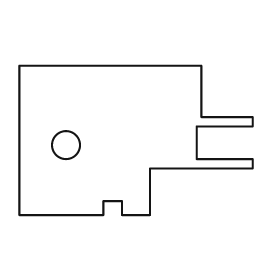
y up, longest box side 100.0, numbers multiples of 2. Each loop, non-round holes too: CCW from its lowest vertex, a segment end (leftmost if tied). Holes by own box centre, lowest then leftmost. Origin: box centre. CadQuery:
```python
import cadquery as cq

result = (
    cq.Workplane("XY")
    .moveTo(-50.0, -32.0)
    .lineTo(-14.0, -32.0)
    .lineTo(-14.0, -26.0)
    .lineTo(-6.0, -26.0)
    .lineTo(-6.0, -32.0)
    .lineTo(6.0, -32.0)
    .lineTo(6.0, -12.0)
    .lineTo(50.0, -12.0)
    .lineTo(50.0, -8.0)
    .lineTo(26.0, -8.0)
    .lineTo(26.0, 6.0)
    .lineTo(50.0, 6.0)
    .lineTo(50.0, 10.0)
    .lineTo(28.0, 10.0)
    .lineTo(28.0, 32.0)
    .lineTo(-50.0, 32.0)
    .close()
    .moveTo(-30.0, -2.0)
    .circle(6.0)
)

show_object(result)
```